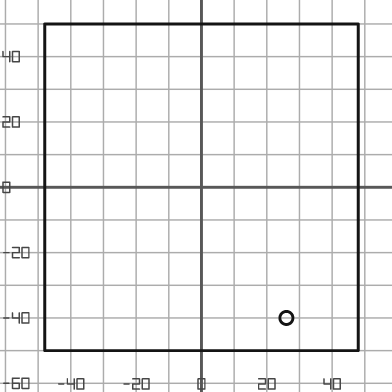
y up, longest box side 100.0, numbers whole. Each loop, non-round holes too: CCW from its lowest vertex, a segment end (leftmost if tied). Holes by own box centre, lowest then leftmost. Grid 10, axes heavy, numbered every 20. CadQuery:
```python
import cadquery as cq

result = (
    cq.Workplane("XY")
    .moveTo(-48.0, -50.0)
    .lineTo(48.0, -50.0)
    .lineTo(48.0, 50.0)
    .lineTo(-48.0, 50.0)
    .close()
    .moveTo(26.0, -40.0)
    .circle(2.0)
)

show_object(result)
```